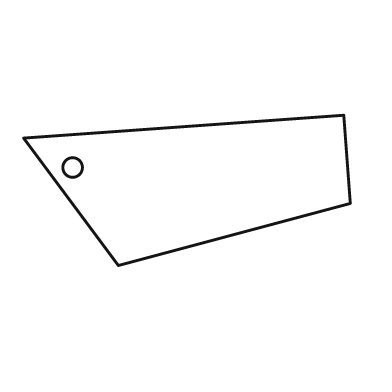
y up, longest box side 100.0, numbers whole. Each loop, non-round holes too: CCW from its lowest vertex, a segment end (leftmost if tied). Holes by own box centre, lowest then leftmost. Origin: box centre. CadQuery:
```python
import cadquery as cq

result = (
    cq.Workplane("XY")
    .moveTo(-21.0, -23.0)
    .lineTo(50.0, -4.0)
    .lineTo(48.0, 23.0)
    .lineTo(-50.0, 16.0)
    .close()
    .moveTo(-35.0, 7.0)
    .circle(3.0)
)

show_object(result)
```